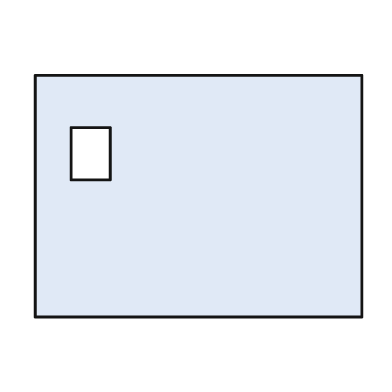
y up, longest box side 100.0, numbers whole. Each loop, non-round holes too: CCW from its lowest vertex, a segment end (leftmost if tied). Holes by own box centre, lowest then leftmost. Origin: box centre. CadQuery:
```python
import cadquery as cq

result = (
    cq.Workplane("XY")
    .moveTo(-50.0, -37.0)
    .lineTo(50.0, -37.0)
    .lineTo(50.0, 37.0)
    .lineTo(-50.0, 37.0)
    .close()
    .moveTo(-39.0, 5.0)
    .lineTo(-27.0, 5.0)
    .lineTo(-27.0, 21.0)
    .lineTo(-39.0, 21.0)
    .close()
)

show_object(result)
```